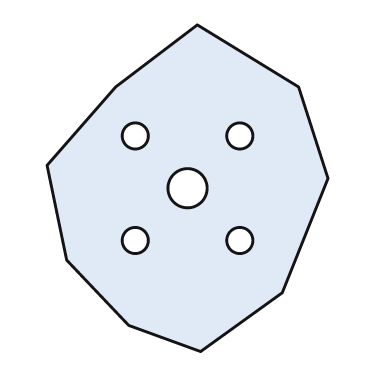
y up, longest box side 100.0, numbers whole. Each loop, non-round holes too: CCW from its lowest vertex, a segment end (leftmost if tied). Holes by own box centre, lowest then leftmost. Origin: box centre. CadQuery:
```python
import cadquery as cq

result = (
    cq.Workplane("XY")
    .moveTo(4.0, -50.0)
    .lineTo(29.0, -32.0)
    .lineTo(43.0, 3.0)
    .lineTo(34.0, 31.0)
    .lineTo(3.0, 50.0)
    .lineTo(-22.0, 31.0)
    .lineTo(-43.0, 7.0)
    .lineTo(-37.0, -22.0)
    .lineTo(-18.0, -42.0)
    .close()
    .moveTo(-16.0, -16.0)
    .circle(4.0)
    .moveTo(16.0, -16.0)
    .circle(4.0)
    .moveTo(0.0, 0.0)
    .circle(6.0)
    .moveTo(-16.0, 16.0)
    .circle(4.0)
    .moveTo(16.0, 16.0)
    .circle(4.0)
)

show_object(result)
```